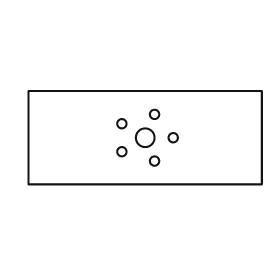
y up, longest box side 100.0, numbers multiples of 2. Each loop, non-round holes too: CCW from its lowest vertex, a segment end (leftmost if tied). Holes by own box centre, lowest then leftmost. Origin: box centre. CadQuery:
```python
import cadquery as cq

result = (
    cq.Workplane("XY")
    .moveTo(-50.0, -20.0)
    .lineTo(50.0, -20.0)
    .lineTo(50.0, 20.0)
    .lineTo(-50.0, 20.0)
    .close()
    .moveTo(4.0, -10.0)
    .circle(2.0)
    .moveTo(-10.0, -6.0)
    .circle(2.0)
    .moveTo(0.0, 0.0)
    .circle(4.0)
    .moveTo(12.0, 0.0)
    .circle(2.0)
    .moveTo(-10.0, 6.0)
    .circle(2.0)
    .moveTo(4.0, 10.0)
    .circle(2.0)
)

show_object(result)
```